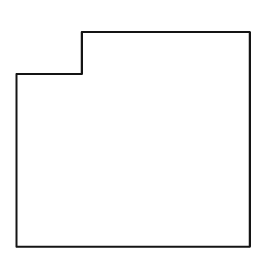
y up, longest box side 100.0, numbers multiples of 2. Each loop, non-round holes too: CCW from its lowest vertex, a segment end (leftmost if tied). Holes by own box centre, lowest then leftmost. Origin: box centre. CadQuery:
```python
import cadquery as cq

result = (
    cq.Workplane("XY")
    .moveTo(-50.0, -46.0)
    .lineTo(50.0, -46.0)
    .lineTo(50.0, 46.0)
    .lineTo(-22.0, 46.0)
    .lineTo(-22.0, 28.0)
    .lineTo(-50.0, 28.0)
    .close()
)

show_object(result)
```